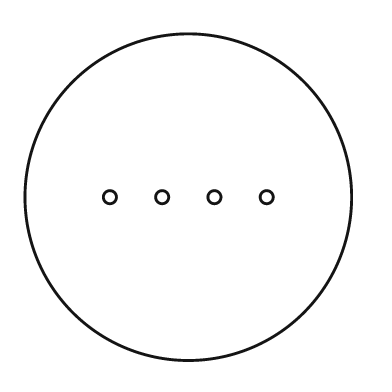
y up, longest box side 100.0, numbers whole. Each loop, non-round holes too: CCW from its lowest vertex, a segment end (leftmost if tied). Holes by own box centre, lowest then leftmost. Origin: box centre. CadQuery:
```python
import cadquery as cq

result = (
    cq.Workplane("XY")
    .moveTo(0.0, 0.0)
    .circle(50.0)
    .moveTo(-24.0, 0.0)
    .circle(2.0)
    .moveTo(-8.0, 0.0)
    .circle(2.0)
    .moveTo(8.0, 0.0)
    .circle(2.0)
    .moveTo(24.0, 0.0)
    .circle(2.0)
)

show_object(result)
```